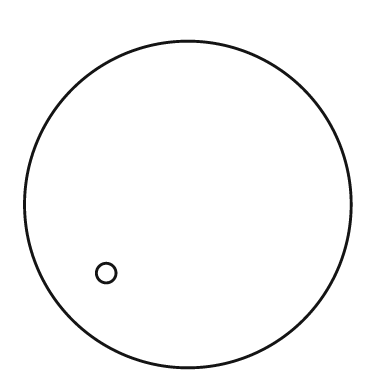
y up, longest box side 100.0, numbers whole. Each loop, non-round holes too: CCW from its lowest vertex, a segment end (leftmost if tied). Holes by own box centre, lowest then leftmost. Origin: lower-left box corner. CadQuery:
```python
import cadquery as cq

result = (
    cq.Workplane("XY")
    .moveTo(50.0, 50.0)
    .circle(50.0)
    .moveTo(25.0, 29.0)
    .circle(3.0)
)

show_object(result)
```